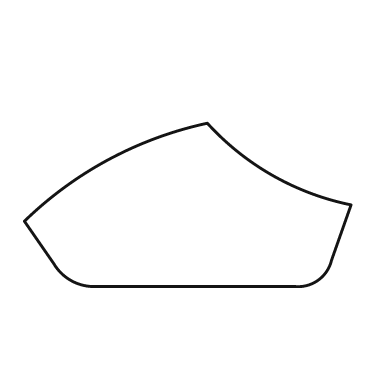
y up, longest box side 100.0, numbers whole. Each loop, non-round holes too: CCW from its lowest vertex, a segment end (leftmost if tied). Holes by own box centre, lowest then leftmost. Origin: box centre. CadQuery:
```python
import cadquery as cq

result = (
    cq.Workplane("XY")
    .moveTo(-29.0, -25.0)
    .lineTo(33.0, -25.0)
    .threePointArc((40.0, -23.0), (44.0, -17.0))
    .lineTo(50.0, 0.0)
    .threePointArc((26.0, 9.0), (6.0, 25.0))
    .threePointArc((-24.0, 14.0), (-50.0, -5.0))
    .lineTo(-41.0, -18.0)
    .threePointArc((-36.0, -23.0), (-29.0, -25.0))
    .close()
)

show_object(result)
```